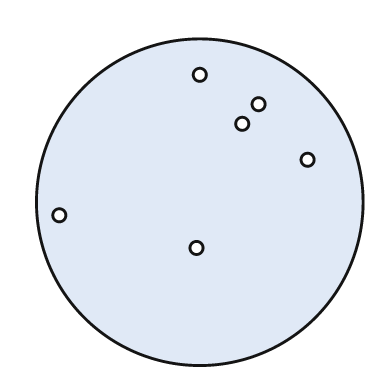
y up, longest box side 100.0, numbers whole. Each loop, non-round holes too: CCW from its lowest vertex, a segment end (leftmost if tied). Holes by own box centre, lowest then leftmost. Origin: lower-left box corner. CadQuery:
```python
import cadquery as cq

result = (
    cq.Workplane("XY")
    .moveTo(50.0, 50.0)
    .circle(50.0)
    .moveTo(49.0, 36.0)
    .circle(2.0)
    .moveTo(7.0, 46.0)
    .circle(2.0)
    .moveTo(83.0, 63.0)
    .circle(2.0)
    .moveTo(63.0, 74.0)
    .circle(2.0)
    .moveTo(68.0, 80.0)
    .circle(2.0)
    .moveTo(50.0, 89.0)
    .circle(2.0)
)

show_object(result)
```